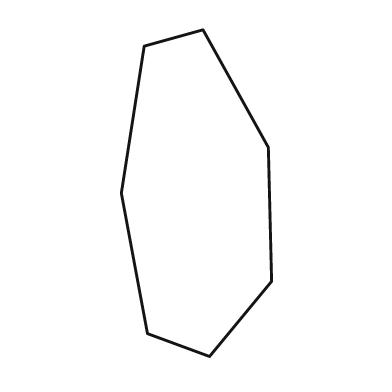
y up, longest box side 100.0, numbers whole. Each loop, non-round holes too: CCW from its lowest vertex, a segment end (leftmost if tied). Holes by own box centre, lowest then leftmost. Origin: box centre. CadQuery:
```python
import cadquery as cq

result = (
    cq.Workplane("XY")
    .moveTo(4.0, -50.0)
    .lineTo(23.0, -27.0)
    .lineTo(22.0, 14.0)
    .lineTo(2.0, 50.0)
    .lineTo(-16.0, 45.0)
    .lineTo(-23.0, 0.0)
    .lineTo(-15.0, -43.0)
    .close()
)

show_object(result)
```